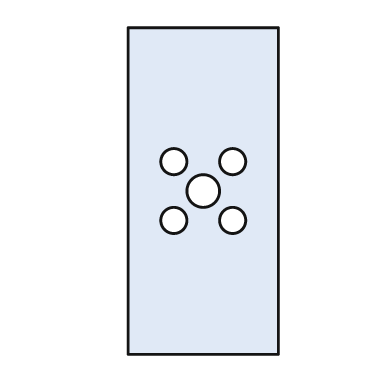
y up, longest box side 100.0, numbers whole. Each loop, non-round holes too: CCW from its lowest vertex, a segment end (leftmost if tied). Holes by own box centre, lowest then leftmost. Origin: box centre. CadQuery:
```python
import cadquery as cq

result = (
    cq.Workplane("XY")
    .moveTo(-23.0, -50.0)
    .lineTo(23.0, -50.0)
    .lineTo(23.0, 50.0)
    .lineTo(-23.0, 50.0)
    .close()
    .moveTo(-9.0, -9.0)
    .circle(4.0)
    .moveTo(9.0, -9.0)
    .circle(4.0)
    .moveTo(0.0, 0.0)
    .circle(5.0)
    .moveTo(-9.0, 9.0)
    .circle(4.0)
    .moveTo(9.0, 9.0)
    .circle(4.0)
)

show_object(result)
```